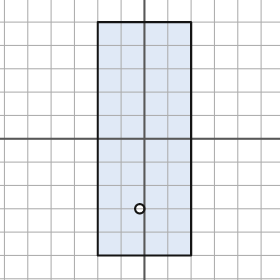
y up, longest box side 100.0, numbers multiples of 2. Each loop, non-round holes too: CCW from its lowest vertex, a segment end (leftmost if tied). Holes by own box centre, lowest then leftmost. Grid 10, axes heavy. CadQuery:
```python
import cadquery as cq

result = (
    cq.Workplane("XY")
    .moveTo(-20.0, -50.0)
    .lineTo(20.0, -50.0)
    .lineTo(20.0, 50.0)
    .lineTo(-20.0, 50.0)
    .close()
    .moveTo(-2.0, -30.0)
    .circle(2.0)
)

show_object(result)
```